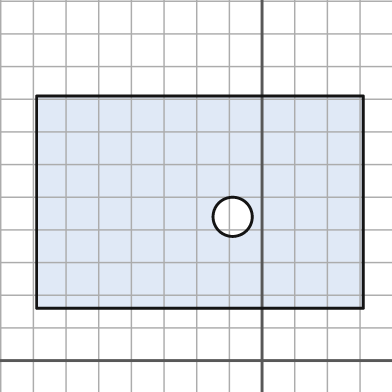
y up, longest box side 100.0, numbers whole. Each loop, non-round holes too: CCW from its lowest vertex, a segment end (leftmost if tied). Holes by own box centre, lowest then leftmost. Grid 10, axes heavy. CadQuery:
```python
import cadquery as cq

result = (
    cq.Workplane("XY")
    .moveTo(-69.0, 16.0)
    .lineTo(31.0, 16.0)
    .lineTo(31.0, 81.0)
    .lineTo(-69.0, 81.0)
    .close()
    .moveTo(-9.0, 44.0)
    .circle(6.0)
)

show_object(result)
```